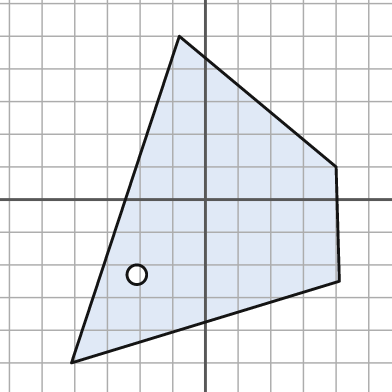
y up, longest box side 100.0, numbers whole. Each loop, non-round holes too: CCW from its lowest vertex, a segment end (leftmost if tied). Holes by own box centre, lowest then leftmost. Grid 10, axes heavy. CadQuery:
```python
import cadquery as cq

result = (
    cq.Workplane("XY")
    .moveTo(-41.0, -50.0)
    .lineTo(41.0, -25.0)
    .lineTo(40.0, 10.0)
    .lineTo(-8.0, 50.0)
    .close()
    .moveTo(-21.0, -23.0)
    .circle(3.0)
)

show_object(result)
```